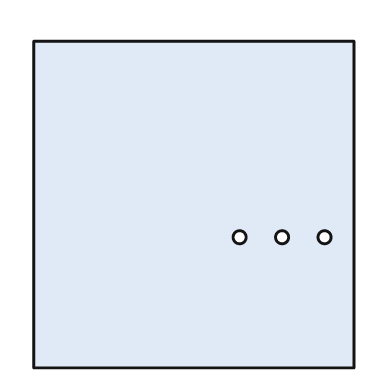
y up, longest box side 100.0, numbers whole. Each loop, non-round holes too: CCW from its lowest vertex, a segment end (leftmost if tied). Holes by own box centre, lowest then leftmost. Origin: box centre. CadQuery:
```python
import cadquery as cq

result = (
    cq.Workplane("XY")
    .moveTo(-49.0, -50.0)
    .lineTo(49.0, -50.0)
    .lineTo(49.0, 50.0)
    .lineTo(-49.0, 50.0)
    .close()
    .moveTo(14.0, -10.0)
    .circle(2.0)
    .moveTo(27.0, -10.0)
    .circle(2.0)
    .moveTo(40.0, -10.0)
    .circle(2.0)
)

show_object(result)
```